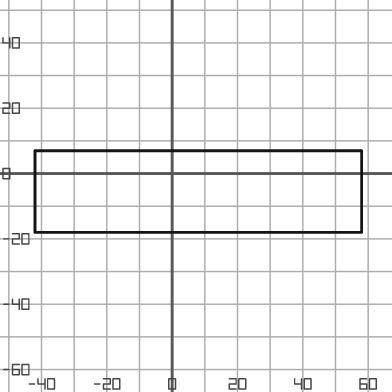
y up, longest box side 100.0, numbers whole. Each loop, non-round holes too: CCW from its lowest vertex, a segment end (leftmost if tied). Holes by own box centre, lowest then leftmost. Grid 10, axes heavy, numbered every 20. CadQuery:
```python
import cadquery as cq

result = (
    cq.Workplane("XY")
    .moveTo(-42.0, -18.0)
    .lineTo(58.0, -18.0)
    .lineTo(58.0, 7.0)
    .lineTo(-42.0, 7.0)
    .close()
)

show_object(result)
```